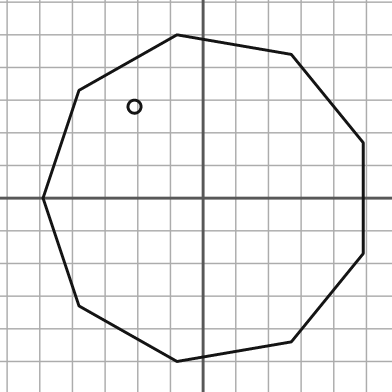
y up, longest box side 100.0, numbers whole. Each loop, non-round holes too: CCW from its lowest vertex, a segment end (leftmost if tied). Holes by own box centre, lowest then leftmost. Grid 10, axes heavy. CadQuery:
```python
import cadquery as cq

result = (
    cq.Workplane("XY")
    .moveTo(-8.0, -50.0)
    .lineTo(27.0, -44.0)
    .lineTo(49.0, -17.0)
    .lineTo(49.0, 17.0)
    .lineTo(27.0, 44.0)
    .lineTo(-8.0, 50.0)
    .lineTo(-38.0, 33.0)
    .lineTo(-49.0, 0.0)
    .lineTo(-38.0, -33.0)
    .close()
    .moveTo(-21.0, 28.0)
    .circle(2.0)
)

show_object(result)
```